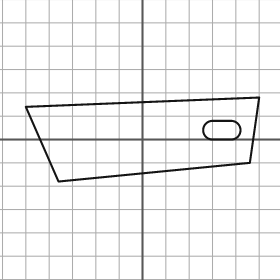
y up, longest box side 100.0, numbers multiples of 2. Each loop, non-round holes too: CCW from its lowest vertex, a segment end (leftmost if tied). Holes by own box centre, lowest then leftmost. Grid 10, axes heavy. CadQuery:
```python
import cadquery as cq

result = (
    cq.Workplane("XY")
    .moveTo(-36.0, -18.0)
    .lineTo(46.0, -10.0)
    .lineTo(50.0, 18.0)
    .lineTo(-50.0, 14.0)
    .close()
    .moveTo(30.0, 0.0)
    .lineTo(38.0, 0.0)
    .threePointArc((42.0, 4.0), (38.0, 8.0))
    .lineTo(30.0, 8.0)
    .threePointArc((26.0, 4.0), (30.0, 0.0))
    .close()
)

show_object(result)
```